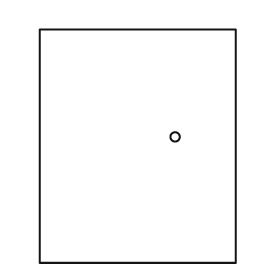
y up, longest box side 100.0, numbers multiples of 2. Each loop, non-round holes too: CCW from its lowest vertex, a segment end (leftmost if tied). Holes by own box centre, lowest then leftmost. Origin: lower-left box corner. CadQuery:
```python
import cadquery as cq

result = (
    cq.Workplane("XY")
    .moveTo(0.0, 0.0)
    .lineTo(84.0, 0.0)
    .lineTo(84.0, 100.0)
    .lineTo(0.0, 100.0)
    .close()
    .moveTo(58.0, 54.0)
    .circle(2.0)
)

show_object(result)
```